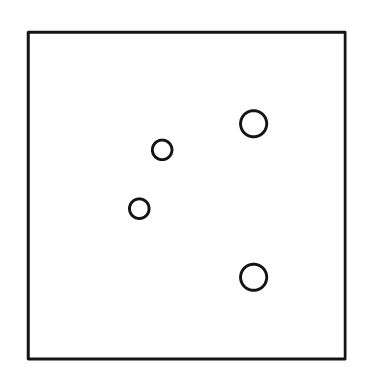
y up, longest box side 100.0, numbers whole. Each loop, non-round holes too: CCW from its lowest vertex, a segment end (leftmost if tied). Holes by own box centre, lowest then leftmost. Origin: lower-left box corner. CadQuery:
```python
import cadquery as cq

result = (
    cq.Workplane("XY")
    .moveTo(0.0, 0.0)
    .lineTo(97.0, 0.0)
    .lineTo(97.0, 100.0)
    .lineTo(0.0, 100.0)
    .close()
    .moveTo(69.0, 25.0)
    .circle(4.0)
    .moveTo(34.0, 46.0)
    .circle(3.0)
    .moveTo(41.0, 64.0)
    .circle(3.0)
    .moveTo(69.0, 72.0)
    .circle(4.0)
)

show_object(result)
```